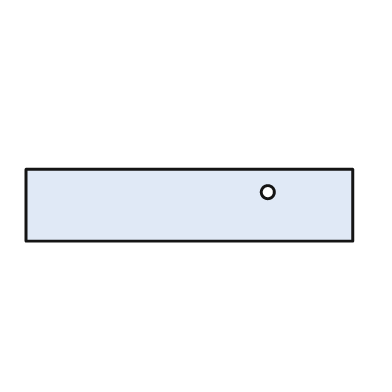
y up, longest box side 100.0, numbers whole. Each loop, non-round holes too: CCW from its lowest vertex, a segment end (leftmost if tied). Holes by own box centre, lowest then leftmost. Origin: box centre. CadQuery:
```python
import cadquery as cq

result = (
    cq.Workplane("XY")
    .moveTo(-50.0, -11.0)
    .lineTo(50.0, -11.0)
    .lineTo(50.0, 11.0)
    .lineTo(-50.0, 11.0)
    .close()
    .moveTo(24.0, 4.0)
    .circle(2.0)
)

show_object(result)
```